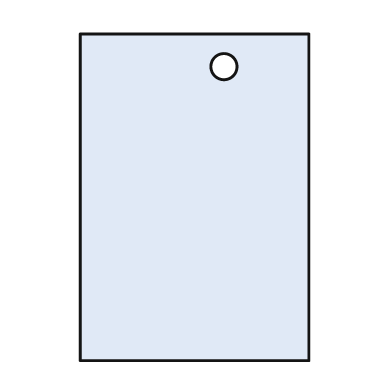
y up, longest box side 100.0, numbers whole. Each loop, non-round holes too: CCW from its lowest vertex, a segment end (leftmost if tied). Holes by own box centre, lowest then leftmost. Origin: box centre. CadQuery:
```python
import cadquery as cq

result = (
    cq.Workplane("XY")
    .moveTo(-35.0, -50.0)
    .lineTo(35.0, -50.0)
    .lineTo(35.0, 50.0)
    .lineTo(-35.0, 50.0)
    .close()
    .moveTo(9.0, 40.0)
    .circle(4.0)
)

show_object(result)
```